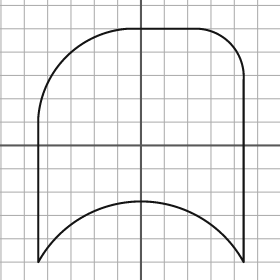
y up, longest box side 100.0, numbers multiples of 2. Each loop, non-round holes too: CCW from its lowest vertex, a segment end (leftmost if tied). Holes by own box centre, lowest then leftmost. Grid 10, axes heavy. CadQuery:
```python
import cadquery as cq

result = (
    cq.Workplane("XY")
    .moveTo(-44.0, -50.0)
    .threePointArc((0.0, -24.0), (44.0, -50.0))
    .lineTo(44.0, 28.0)
    .threePointArc((38.0, 44.0), (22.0, 50.0))
    .lineTo(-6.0, 50.0)
    .threePointArc((-32.0, 38.0), (-44.0, 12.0))
    .close()
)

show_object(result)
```